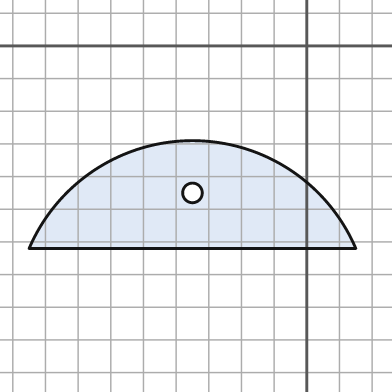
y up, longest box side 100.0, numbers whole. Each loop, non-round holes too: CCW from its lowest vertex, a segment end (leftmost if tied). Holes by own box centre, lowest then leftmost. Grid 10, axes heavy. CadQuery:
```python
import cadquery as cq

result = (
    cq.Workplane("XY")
    .moveTo(-85.0, -62.0)
    .lineTo(15.0, -62.0)
    .threePointArc((-35.0, -29.0), (-85.0, -62.0))
    .close()
    .moveTo(-35.0, -45.0)
    .circle(3.0)
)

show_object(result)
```